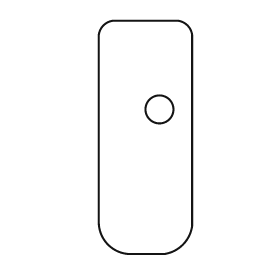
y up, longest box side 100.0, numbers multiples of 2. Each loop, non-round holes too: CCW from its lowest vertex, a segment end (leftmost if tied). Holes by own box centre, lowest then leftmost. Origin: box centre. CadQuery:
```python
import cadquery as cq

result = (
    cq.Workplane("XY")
    .moveTo(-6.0, -50.0)
    .lineTo(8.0, -50.0)
    .threePointArc((16.0, -46.0), (20.0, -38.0))
    .lineTo(20.0, 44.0)
    .threePointArc((18.0, 48.0), (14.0, 50.0))
    .lineTo(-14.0, 50.0)
    .threePointArc((-18.0, 48.0), (-20.0, 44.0))
    .lineTo(-20.0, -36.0)
    .threePointArc((-16.0, -46.0), (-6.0, -50.0))
    .close()
    .moveTo(6.0, 12.0)
    .circle(6.0)
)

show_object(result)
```